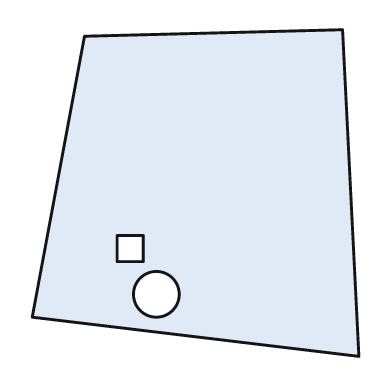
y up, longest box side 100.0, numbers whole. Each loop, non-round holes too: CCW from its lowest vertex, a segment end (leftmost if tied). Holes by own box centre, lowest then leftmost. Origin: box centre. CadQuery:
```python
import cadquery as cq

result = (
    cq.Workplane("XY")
    .moveTo(50.0, -50.0)
    .lineTo(45.0, 50.0)
    .lineTo(-34.0, 48.0)
    .lineTo(-50.0, -38.0)
    .close()
    .moveTo(-12.0, -31.0)
    .circle(7.0)
    .moveTo(-24.0, -21.0)
    .lineTo(-16.0, -21.0)
    .lineTo(-16.0, -13.0)
    .lineTo(-24.0, -13.0)
    .close()
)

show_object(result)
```